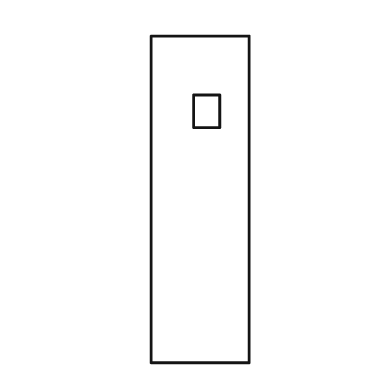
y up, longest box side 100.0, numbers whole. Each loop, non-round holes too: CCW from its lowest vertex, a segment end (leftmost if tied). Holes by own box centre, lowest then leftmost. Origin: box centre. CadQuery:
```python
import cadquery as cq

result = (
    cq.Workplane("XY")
    .moveTo(-15.0, -50.0)
    .lineTo(15.0, -50.0)
    .lineTo(15.0, 50.0)
    .lineTo(-15.0, 50.0)
    .close()
    .moveTo(-2.0, 22.0)
    .lineTo(6.0, 22.0)
    .lineTo(6.0, 32.0)
    .lineTo(-2.0, 32.0)
    .close()
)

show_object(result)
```